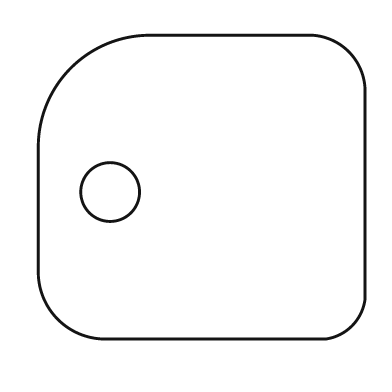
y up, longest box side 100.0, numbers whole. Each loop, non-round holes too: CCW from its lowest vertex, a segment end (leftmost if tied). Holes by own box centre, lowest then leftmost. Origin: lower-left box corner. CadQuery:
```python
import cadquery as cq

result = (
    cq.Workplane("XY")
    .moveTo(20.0, 0.0)
    .lineTo(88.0, 0.0)
    .threePointArc((96.0, 4.0), (100.0, 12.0))
    .lineTo(100.0, 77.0)
    .threePointArc((95.0, 88.0), (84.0, 93.0))
    .lineTo(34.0, 93.0)
    .threePointArc((10.0, 83.0), (0.0, 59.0))
    .lineTo(0.0, 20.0)
    .threePointArc((6.0, 6.0), (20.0, 0.0))
    .close()
    .moveTo(22.0, 45.0)
    .circle(9.0)
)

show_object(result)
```